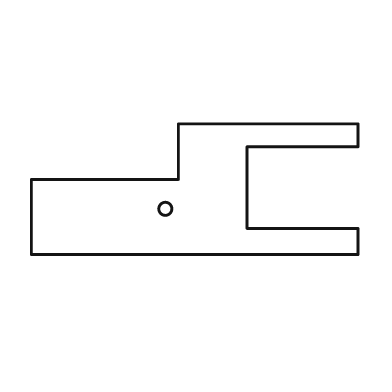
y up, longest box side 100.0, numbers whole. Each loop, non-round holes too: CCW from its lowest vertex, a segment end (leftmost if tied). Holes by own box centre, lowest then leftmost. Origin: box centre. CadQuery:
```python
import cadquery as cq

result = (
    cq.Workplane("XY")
    .moveTo(-50.0, -20.0)
    .lineTo(50.0, -20.0)
    .lineTo(50.0, -12.0)
    .lineTo(16.0, -12.0)
    .lineTo(16.0, 13.0)
    .lineTo(50.0, 13.0)
    .lineTo(50.0, 20.0)
    .lineTo(-5.0, 20.0)
    .lineTo(-5.0, 3.0)
    .lineTo(-50.0, 3.0)
    .close()
    .moveTo(-9.0, -6.0)
    .circle(2.0)
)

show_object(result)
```